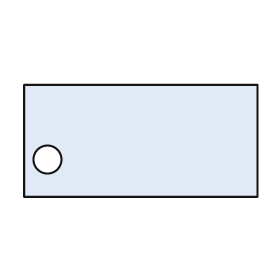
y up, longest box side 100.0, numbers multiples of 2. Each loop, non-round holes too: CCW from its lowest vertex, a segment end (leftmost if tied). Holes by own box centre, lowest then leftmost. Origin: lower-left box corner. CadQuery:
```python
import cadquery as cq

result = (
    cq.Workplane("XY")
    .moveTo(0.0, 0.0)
    .lineTo(100.0, 0.0)
    .lineTo(100.0, 48.0)
    .lineTo(0.0, 48.0)
    .close()
    .moveTo(10.0, 16.0)
    .circle(6.0)
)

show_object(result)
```